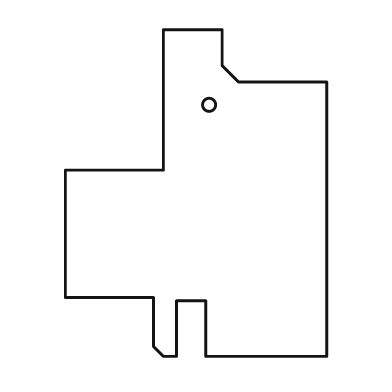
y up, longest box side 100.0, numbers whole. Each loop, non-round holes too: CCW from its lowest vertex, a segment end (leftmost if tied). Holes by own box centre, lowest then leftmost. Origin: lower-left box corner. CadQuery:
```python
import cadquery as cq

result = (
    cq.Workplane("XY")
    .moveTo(30.0, 0.0)
    .lineTo(34.0, 0.0)
    .lineTo(34.0, 17.0)
    .lineTo(43.0, 17.0)
    .lineTo(43.0, 0.0)
    .lineTo(80.0, 0.0)
    .lineTo(80.0, 84.0)
    .lineTo(53.0, 84.0)
    .lineTo(48.0, 89.0)
    .lineTo(48.0, 100.0)
    .lineTo(30.0, 100.0)
    .lineTo(30.0, 57.0)
    .lineTo(0.0, 57.0)
    .lineTo(0.0, 18.0)
    .lineTo(27.0, 18.0)
    .lineTo(27.0, 3.0)
    .close()
    .moveTo(44.0, 77.0)
    .circle(2.0)
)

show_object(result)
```